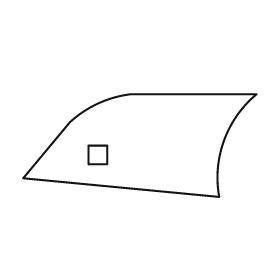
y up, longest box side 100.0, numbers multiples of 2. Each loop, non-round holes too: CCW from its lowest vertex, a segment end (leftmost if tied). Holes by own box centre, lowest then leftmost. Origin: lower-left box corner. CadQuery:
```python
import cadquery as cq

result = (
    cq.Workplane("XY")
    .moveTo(84.0, 0.0)
    .threePointArc((86.0, 24.0), (100.0, 44.0))
    .lineTo(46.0, 44.0)
    .threePointArc((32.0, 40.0), (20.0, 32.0))
    .lineTo(0.0, 8.0)
    .close()
    .moveTo(28.0, 14.0)
    .lineTo(36.0, 14.0)
    .lineTo(36.0, 22.0)
    .lineTo(28.0, 22.0)
    .close()
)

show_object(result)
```